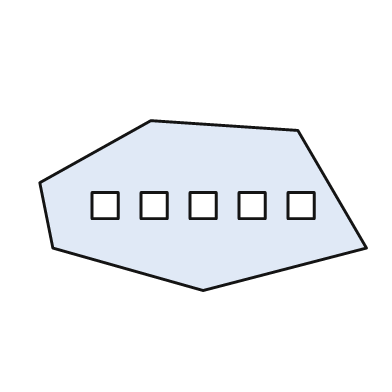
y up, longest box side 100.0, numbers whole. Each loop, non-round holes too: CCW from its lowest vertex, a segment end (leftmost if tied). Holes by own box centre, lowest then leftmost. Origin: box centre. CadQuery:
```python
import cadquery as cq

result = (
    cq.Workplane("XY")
    .moveTo(0.0, -26.0)
    .lineTo(50.0, -13.0)
    .lineTo(29.0, 23.0)
    .lineTo(-16.0, 26.0)
    .lineTo(-50.0, 7.0)
    .lineTo(-46.0, -13.0)
    .close()
    .moveTo(-34.0, -4.0)
    .lineTo(-26.0, -4.0)
    .lineTo(-26.0, 4.0)
    .lineTo(-34.0, 4.0)
    .close()
    .moveTo(-19.0, -4.0)
    .lineTo(-11.0, -4.0)
    .lineTo(-11.0, 4.0)
    .lineTo(-19.0, 4.0)
    .close()
    .moveTo(-4.0, -4.0)
    .lineTo(4.0, -4.0)
    .lineTo(4.0, 4.0)
    .lineTo(-4.0, 4.0)
    .close()
    .moveTo(11.0, -4.0)
    .lineTo(19.0, -4.0)
    .lineTo(19.0, 4.0)
    .lineTo(11.0, 4.0)
    .close()
    .moveTo(26.0, -4.0)
    .lineTo(34.0, -4.0)
    .lineTo(34.0, 4.0)
    .lineTo(26.0, 4.0)
    .close()
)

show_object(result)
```